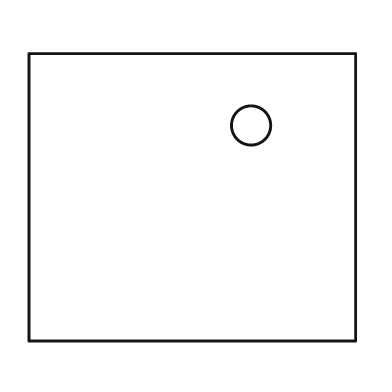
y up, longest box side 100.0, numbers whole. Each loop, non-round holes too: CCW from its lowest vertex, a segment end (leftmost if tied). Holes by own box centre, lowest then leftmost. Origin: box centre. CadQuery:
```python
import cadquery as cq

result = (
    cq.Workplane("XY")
    .moveTo(-50.0, -44.0)
    .lineTo(50.0, -44.0)
    .lineTo(50.0, 44.0)
    .lineTo(-50.0, 44.0)
    .close()
    .moveTo(18.0, 22.0)
    .circle(6.0)
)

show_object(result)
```